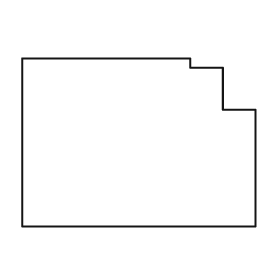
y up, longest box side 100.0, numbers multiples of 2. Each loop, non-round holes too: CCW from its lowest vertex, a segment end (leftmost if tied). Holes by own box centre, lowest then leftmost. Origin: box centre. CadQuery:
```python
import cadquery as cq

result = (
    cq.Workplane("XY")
    .moveTo(-50.0, -36.0)
    .lineTo(50.0, -36.0)
    .lineTo(50.0, 14.0)
    .lineTo(36.0, 14.0)
    .lineTo(36.0, 32.0)
    .lineTo(22.0, 32.0)
    .lineTo(22.0, 36.0)
    .lineTo(-50.0, 36.0)
    .close()
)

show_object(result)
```